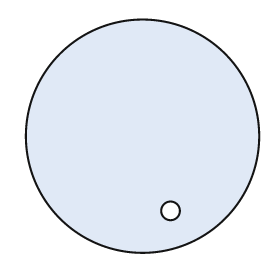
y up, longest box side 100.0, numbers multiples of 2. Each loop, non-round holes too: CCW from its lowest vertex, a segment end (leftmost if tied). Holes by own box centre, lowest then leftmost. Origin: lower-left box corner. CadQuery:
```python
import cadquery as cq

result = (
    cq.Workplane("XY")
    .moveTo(50.0, 50.0)
    .circle(50.0)
    .moveTo(62.0, 18.0)
    .circle(4.0)
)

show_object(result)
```